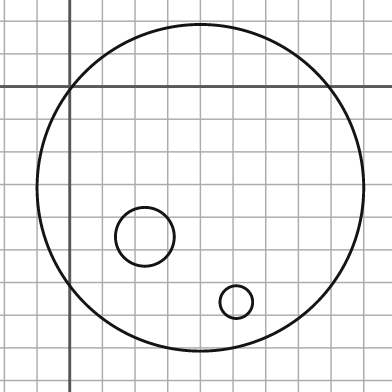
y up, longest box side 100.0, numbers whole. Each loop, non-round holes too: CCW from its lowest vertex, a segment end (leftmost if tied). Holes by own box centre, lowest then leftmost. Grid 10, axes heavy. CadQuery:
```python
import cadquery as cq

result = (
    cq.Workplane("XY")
    .moveTo(40.0, -31.0)
    .circle(50.0)
    .moveTo(51.0, -66.0)
    .circle(5.0)
    .moveTo(23.0, -46.0)
    .circle(9.0)
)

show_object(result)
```